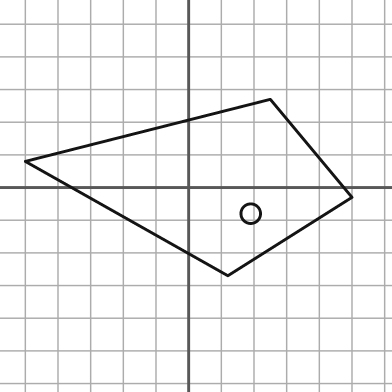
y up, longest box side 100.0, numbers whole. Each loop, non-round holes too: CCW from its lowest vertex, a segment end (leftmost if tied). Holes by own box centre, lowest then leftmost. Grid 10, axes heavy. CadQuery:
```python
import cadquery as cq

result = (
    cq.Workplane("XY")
    .moveTo(12.0, -27.0)
    .lineTo(50.0, -3.0)
    .lineTo(25.0, 27.0)
    .lineTo(-50.0, 8.0)
    .close()
    .moveTo(19.0, -8.0)
    .circle(3.0)
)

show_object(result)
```